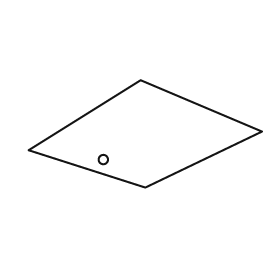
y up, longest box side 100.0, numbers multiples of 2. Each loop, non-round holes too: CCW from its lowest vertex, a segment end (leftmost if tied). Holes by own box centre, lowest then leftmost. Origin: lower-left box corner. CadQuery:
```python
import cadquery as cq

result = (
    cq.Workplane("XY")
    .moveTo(50.0, 0.0)
    .lineTo(100.0, 24.0)
    .lineTo(48.0, 46.0)
    .lineTo(0.0, 16.0)
    .close()
    .moveTo(32.0, 12.0)
    .circle(2.0)
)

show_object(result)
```